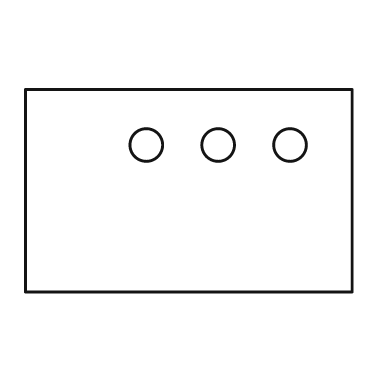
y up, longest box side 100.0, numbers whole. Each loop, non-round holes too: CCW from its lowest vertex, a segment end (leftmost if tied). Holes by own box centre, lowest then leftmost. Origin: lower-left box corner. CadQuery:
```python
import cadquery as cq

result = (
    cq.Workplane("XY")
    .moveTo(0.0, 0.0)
    .lineTo(100.0, 0.0)
    .lineTo(100.0, 62.0)
    .lineTo(0.0, 62.0)
    .close()
    .moveTo(37.0, 45.0)
    .circle(5.0)
    .moveTo(59.0, 45.0)
    .circle(5.0)
    .moveTo(81.0, 45.0)
    .circle(5.0)
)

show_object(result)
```